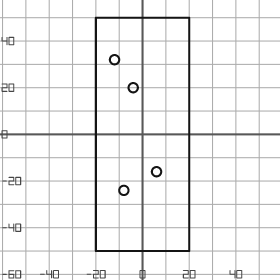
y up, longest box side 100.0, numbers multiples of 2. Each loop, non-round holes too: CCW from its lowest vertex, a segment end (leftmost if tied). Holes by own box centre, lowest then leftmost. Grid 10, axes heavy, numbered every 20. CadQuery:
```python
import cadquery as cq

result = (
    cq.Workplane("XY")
    .moveTo(-20.0, -50.0)
    .lineTo(20.0, -50.0)
    .lineTo(20.0, 50.0)
    .lineTo(-20.0, 50.0)
    .close()
    .moveTo(-8.0, -24.0)
    .circle(2.0)
    .moveTo(6.0, -16.0)
    .circle(2.0)
    .moveTo(-4.0, 20.0)
    .circle(2.0)
    .moveTo(-12.0, 32.0)
    .circle(2.0)
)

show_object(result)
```